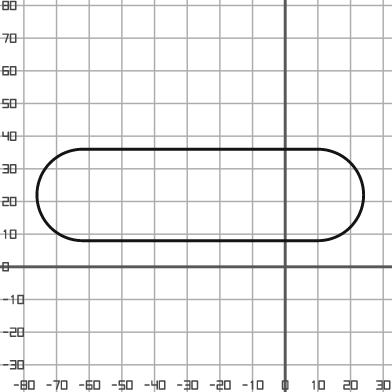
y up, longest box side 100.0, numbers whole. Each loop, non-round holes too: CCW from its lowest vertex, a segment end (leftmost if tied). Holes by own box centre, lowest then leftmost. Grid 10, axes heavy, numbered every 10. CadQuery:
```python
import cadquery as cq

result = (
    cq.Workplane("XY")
    .moveTo(-62.0, 8.0)
    .lineTo(10.0, 8.0)
    .threePointArc((24.0, 22.0), (10.0, 36.0))
    .lineTo(-62.0, 36.0)
    .threePointArc((-76.0, 22.0), (-62.0, 8.0))
    .close()
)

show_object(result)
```